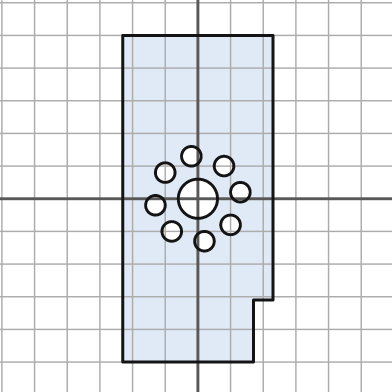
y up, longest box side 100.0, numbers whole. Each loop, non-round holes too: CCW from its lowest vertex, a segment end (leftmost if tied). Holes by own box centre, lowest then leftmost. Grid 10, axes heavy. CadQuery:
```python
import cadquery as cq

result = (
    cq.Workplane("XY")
    .moveTo(-23.0, -50.0)
    .lineTo(17.0, -50.0)
    .lineTo(17.0, -31.0)
    .lineTo(23.0, -31.0)
    .lineTo(23.0, 50.0)
    .lineTo(-23.0, 50.0)
    .close()
    .moveTo(2.0, -13.0)
    .circle(3.0)
    .moveTo(-8.0, -10.0)
    .circle(3.0)
    .moveTo(10.0, -8.0)
    .circle(3.0)
    .moveTo(-13.0, -2.0)
    .circle(3.0)
    .moveTo(0.0, 0.0)
    .circle(6.0)
    .moveTo(13.0, 2.0)
    .circle(3.0)
    .moveTo(-10.0, 8.0)
    .circle(3.0)
    .moveTo(8.0, 10.0)
    .circle(3.0)
    .moveTo(-2.0, 13.0)
    .circle(3.0)
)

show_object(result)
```